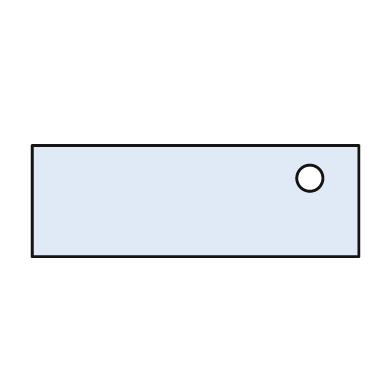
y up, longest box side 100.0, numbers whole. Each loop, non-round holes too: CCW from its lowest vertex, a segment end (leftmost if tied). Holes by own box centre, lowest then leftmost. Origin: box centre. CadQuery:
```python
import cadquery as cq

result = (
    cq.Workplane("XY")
    .moveTo(-50.0, -17.0)
    .lineTo(50.0, -17.0)
    .lineTo(50.0, 17.0)
    .lineTo(-50.0, 17.0)
    .close()
    .moveTo(35.0, 7.0)
    .circle(4.0)
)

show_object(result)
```